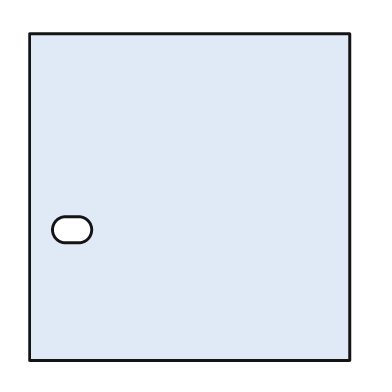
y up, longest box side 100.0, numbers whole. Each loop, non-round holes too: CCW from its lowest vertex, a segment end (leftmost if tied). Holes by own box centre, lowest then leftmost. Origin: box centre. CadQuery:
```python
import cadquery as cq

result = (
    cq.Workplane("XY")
    .moveTo(-49.0, -50.0)
    .lineTo(49.0, -50.0)
    .lineTo(49.0, 50.0)
    .lineTo(-49.0, 50.0)
    .close()
    .moveTo(-38.0, -14.0)
    .lineTo(-34.0, -14.0)
    .threePointArc((-30.0, -10.0), (-34.0, -6.0))
    .lineTo(-38.0, -6.0)
    .threePointArc((-42.0, -10.0), (-38.0, -14.0))
    .close()
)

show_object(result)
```